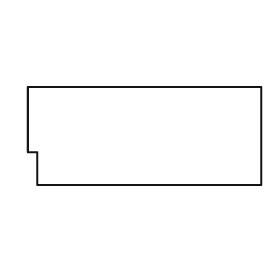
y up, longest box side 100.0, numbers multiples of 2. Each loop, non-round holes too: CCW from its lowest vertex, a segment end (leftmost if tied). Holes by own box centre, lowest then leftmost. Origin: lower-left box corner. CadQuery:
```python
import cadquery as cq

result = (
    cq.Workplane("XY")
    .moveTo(4.0, 0.0)
    .lineTo(100.0, 0.0)
    .lineTo(100.0, 42.0)
    .lineTo(0.0, 42.0)
    .lineTo(0.0, 14.0)
    .lineTo(4.0, 14.0)
    .close()
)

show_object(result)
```